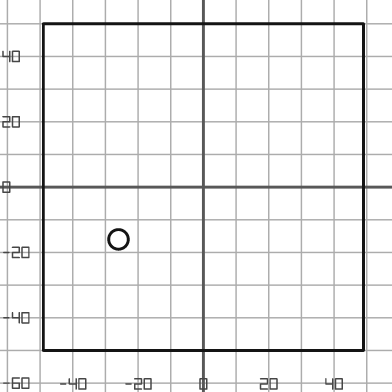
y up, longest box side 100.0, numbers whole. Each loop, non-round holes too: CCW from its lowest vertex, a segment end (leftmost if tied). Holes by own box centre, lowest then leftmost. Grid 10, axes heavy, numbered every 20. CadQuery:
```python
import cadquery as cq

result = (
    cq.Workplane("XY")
    .moveTo(-49.0, -50.0)
    .lineTo(49.0, -50.0)
    .lineTo(49.0, 50.0)
    .lineTo(-49.0, 50.0)
    .close()
    .moveTo(-26.0, -16.0)
    .circle(3.0)
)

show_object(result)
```